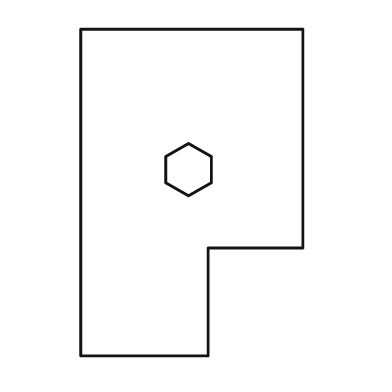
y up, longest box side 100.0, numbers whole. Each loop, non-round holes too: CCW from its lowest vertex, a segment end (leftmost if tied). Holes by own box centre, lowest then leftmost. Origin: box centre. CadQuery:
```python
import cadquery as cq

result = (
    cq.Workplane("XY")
    .moveTo(-34.0, -50.0)
    .lineTo(5.0, -50.0)
    .lineTo(5.0, -17.0)
    .lineTo(34.0, -17.0)
    .lineTo(34.0, 50.0)
    .lineTo(-34.0, 50.0)
    .close()
    .moveTo(-1.0, -1.0)
    .lineTo(6.0, 3.0)
    .lineTo(6.0, 11.0)
    .lineTo(-1.0, 15.0)
    .lineTo(-8.0, 11.0)
    .lineTo(-8.0, 3.0)
    .close()
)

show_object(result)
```